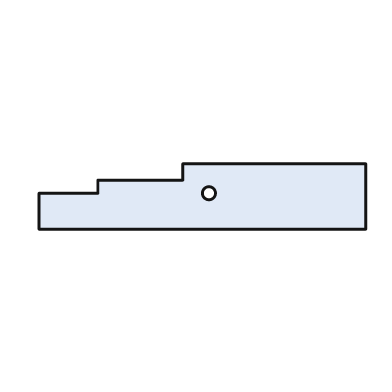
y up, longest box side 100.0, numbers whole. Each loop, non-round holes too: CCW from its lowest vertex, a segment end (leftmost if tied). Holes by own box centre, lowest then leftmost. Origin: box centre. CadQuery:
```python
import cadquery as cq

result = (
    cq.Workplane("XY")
    .moveTo(-50.0, -10.0)
    .lineTo(50.0, -10.0)
    .lineTo(50.0, 10.0)
    .lineTo(-6.0, 10.0)
    .lineTo(-6.0, 5.0)
    .lineTo(-32.0, 5.0)
    .lineTo(-32.0, 1.0)
    .lineTo(-50.0, 1.0)
    .close()
    .moveTo(2.0, 1.0)
    .circle(2.0)
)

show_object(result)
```